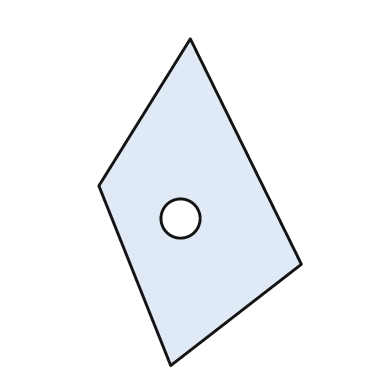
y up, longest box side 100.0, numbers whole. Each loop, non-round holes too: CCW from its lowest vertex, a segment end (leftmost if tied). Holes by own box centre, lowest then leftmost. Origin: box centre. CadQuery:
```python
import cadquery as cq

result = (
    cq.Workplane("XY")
    .moveTo(-9.0, -50.0)
    .lineTo(31.0, -19.0)
    .lineTo(-3.0, 50.0)
    .lineTo(-31.0, 5.0)
    .close()
    .moveTo(-6.0, -5.0)
    .circle(6.0)
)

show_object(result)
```